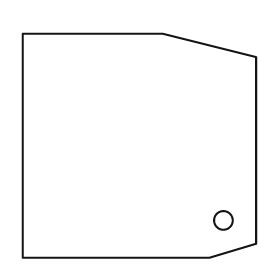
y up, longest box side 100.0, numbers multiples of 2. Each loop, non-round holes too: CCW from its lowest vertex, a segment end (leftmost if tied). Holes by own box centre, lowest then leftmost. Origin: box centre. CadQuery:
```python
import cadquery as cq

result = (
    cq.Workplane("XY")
    .moveTo(-50.0, -48.0)
    .lineTo(30.0, -48.0)
    .lineTo(50.0, -42.0)
    .lineTo(50.0, 38.0)
    .lineTo(10.0, 48.0)
    .lineTo(-50.0, 48.0)
    .close()
    .moveTo(36.0, -32.0)
    .circle(4.0)
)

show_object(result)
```